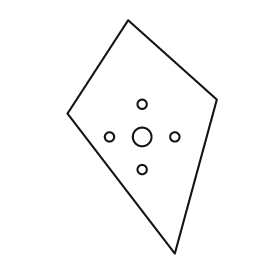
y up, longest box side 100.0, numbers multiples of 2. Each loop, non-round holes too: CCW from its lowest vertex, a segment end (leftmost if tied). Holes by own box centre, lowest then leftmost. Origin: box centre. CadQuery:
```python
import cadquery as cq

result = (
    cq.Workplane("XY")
    .moveTo(14.0, -50.0)
    .lineTo(32.0, 16.0)
    .lineTo(-6.0, 50.0)
    .lineTo(-32.0, 10.0)
    .close()
    .moveTo(0.0, -14.0)
    .circle(2.0)
    .moveTo(-14.0, 0.0)
    .circle(2.0)
    .moveTo(0.0, 0.0)
    .circle(4.0)
    .moveTo(14.0, 0.0)
    .circle(2.0)
    .moveTo(0.0, 14.0)
    .circle(2.0)
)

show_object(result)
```